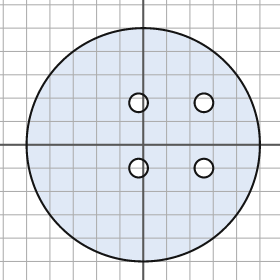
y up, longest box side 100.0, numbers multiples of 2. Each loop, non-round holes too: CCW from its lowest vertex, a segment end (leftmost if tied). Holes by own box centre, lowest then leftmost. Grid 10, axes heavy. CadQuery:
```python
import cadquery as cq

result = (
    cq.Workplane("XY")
    .moveTo(0.0, 0.0)
    .circle(50.0)
    .moveTo(-2.0, -10.0)
    .circle(4.0)
    .moveTo(26.0, -10.0)
    .circle(4.0)
    .moveTo(-2.0, 18.0)
    .circle(4.0)
    .moveTo(26.0, 18.0)
    .circle(4.0)
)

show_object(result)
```